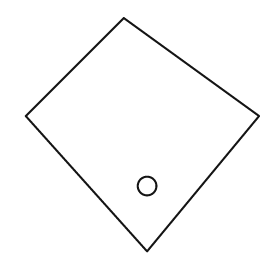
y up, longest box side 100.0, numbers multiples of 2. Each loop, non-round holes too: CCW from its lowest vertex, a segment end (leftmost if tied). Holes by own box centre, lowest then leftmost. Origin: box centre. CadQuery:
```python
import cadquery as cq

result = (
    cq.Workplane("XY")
    .moveTo(2.0, -50.0)
    .lineTo(50.0, 8.0)
    .lineTo(-8.0, 50.0)
    .lineTo(-50.0, 8.0)
    .close()
    .moveTo(2.0, -22.0)
    .circle(4.0)
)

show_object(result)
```